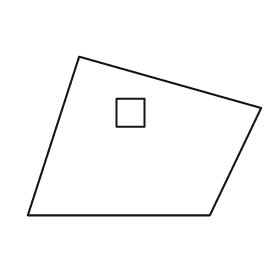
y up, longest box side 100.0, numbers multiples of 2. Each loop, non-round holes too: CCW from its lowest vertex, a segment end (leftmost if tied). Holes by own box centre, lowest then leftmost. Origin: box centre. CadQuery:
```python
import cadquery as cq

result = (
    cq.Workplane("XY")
    .moveTo(-50.0, -34.0)
    .lineTo(28.0, -34.0)
    .lineTo(50.0, 12.0)
    .lineTo(-28.0, 34.0)
    .close()
    .moveTo(-12.0, 4.0)
    .lineTo(0.0, 4.0)
    .lineTo(0.0, 16.0)
    .lineTo(-12.0, 16.0)
    .close()
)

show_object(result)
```